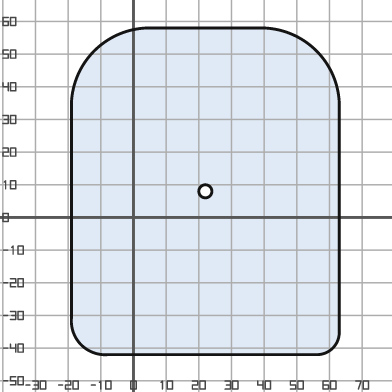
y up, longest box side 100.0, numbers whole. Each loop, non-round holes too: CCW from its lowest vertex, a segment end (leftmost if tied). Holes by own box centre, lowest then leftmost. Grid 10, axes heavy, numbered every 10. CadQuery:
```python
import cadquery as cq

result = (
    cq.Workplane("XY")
    .moveTo(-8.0, -42.0)
    .lineTo(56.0, -42.0)
    .threePointArc((61.0, -40.0), (63.0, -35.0))
    .lineTo(63.0, 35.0)
    .threePointArc((56.0, 51.0), (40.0, 58.0))
    .lineTo(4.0, 58.0)
    .threePointArc((-12.0, 51.0), (-19.0, 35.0))
    .lineTo(-19.0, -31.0)
    .threePointArc((-16.0, -39.0), (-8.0, -42.0))
    .close()
    .moveTo(22.0, 8.0)
    .circle(2.0)
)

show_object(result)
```